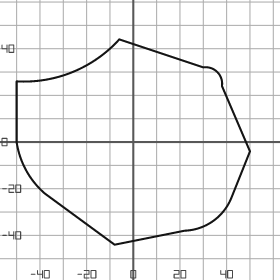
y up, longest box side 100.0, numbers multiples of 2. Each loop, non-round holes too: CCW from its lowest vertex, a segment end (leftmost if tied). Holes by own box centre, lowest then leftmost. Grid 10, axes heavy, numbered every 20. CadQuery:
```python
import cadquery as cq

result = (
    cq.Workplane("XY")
    .moveTo(-8.0, -44.0)
    .lineTo(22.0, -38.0)
    .threePointArc((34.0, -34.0), (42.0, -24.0))
    .lineTo(50.0, -4.0)
    .lineTo(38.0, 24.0)
    .threePointArc((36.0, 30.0), (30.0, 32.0))
    .lineTo(-6.0, 44.0)
    .threePointArc((-26.0, 30.0), (-50.0, 26.0))
    .lineTo(-50.0, 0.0)
    .threePointArc((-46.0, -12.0), (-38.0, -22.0))
    .close()
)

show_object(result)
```